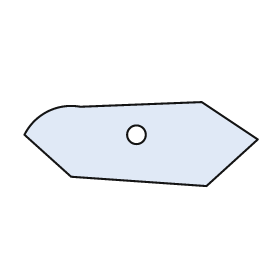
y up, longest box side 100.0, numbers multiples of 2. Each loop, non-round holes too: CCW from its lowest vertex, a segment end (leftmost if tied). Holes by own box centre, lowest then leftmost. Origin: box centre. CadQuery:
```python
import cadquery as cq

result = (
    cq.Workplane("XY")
    .moveTo(28.0, -18.0)
    .lineTo(50.0, 2.0)
    .lineTo(26.0, 18.0)
    .lineTo(-26.0, 16.0)
    .threePointArc((-40.0, 14.0), (-50.0, 4.0))
    .lineTo(-30.0, -14.0)
    .close()
    .moveTo(-2.0, 4.0)
    .circle(4.0)
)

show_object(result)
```